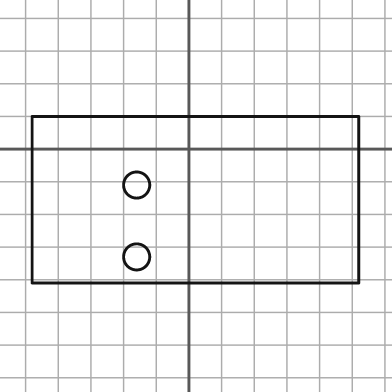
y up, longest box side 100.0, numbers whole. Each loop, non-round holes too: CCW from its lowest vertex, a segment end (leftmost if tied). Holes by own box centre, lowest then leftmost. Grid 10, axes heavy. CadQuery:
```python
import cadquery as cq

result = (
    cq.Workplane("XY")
    .moveTo(-48.0, -41.0)
    .lineTo(52.0, -41.0)
    .lineTo(52.0, 10.0)
    .lineTo(-48.0, 10.0)
    .close()
    .moveTo(-16.0, -33.0)
    .circle(4.0)
    .moveTo(-16.0, -11.0)
    .circle(4.0)
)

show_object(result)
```